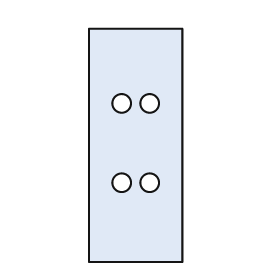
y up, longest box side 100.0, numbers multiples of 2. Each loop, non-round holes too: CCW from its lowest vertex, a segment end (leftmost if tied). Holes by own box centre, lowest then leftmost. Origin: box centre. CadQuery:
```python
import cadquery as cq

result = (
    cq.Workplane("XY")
    .moveTo(-20.0, -50.0)
    .lineTo(20.0, -50.0)
    .lineTo(20.0, 50.0)
    .lineTo(-20.0, 50.0)
    .close()
    .moveTo(-6.0, -16.0)
    .circle(4.0)
    .moveTo(6.0, -16.0)
    .circle(4.0)
    .moveTo(-6.0, 18.0)
    .circle(4.0)
    .moveTo(6.0, 18.0)
    .circle(4.0)
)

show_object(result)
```